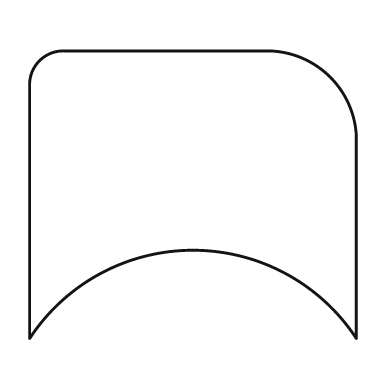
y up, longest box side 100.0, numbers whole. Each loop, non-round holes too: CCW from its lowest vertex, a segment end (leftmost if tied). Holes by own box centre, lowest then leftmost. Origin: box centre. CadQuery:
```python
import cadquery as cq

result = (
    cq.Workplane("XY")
    .moveTo(-50.0, -44.0)
    .threePointArc((0.0, -17.0), (50.0, -44.0))
    .lineTo(50.0, 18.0)
    .threePointArc((42.0, 36.0), (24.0, 44.0))
    .lineTo(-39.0, 44.0)
    .threePointArc((-47.0, 41.0), (-50.0, 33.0))
    .close()
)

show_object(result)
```